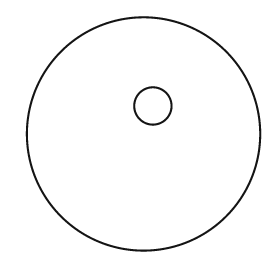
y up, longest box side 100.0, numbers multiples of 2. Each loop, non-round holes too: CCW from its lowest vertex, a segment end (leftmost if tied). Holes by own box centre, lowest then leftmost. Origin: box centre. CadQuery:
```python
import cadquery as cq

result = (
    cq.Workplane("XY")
    .moveTo(0.0, 0.0)
    .circle(50.0)
    .moveTo(4.0, 12.0)
    .circle(8.0)
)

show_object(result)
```